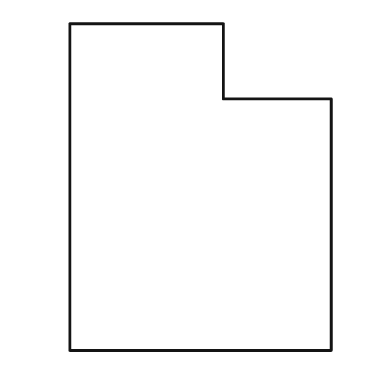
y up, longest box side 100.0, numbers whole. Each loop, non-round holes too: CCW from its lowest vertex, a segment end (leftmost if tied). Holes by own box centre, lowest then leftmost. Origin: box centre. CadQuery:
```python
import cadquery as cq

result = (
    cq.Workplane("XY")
    .moveTo(-40.0, -50.0)
    .lineTo(40.0, -50.0)
    .lineTo(40.0, 27.0)
    .lineTo(7.0, 27.0)
    .lineTo(7.0, 50.0)
    .lineTo(-40.0, 50.0)
    .close()
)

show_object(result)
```